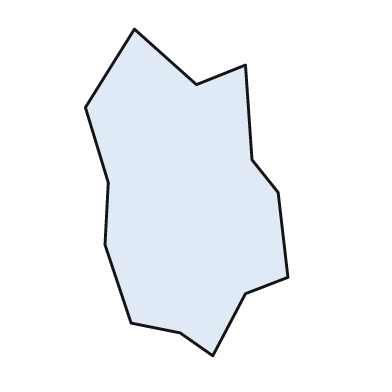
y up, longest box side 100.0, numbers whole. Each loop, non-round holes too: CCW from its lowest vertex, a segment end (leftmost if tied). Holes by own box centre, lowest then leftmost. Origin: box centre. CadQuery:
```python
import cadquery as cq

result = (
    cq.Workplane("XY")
    .moveTo(8.0, -50.0)
    .lineTo(18.0, -31.0)
    .lineTo(31.0, -26.0)
    .lineTo(28.0, 0.0)
    .lineTo(20.0, 10.0)
    .lineTo(18.0, 39.0)
    .lineTo(3.0, 33.0)
    .lineTo(-16.0, 50.0)
    .lineTo(-31.0, 26.0)
    .lineTo(-24.0, 3.0)
    .lineTo(-25.0, -16.0)
    .lineTo(-17.0, -40.0)
    .lineTo(-2.0, -43.0)
    .close()
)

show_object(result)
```